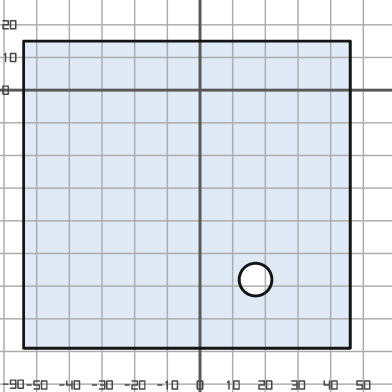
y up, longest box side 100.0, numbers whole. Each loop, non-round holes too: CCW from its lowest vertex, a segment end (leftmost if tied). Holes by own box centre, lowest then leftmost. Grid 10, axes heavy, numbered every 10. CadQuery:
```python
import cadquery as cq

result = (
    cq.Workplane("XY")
    .moveTo(-54.0, -79.0)
    .lineTo(46.0, -79.0)
    .lineTo(46.0, 15.0)
    .lineTo(-54.0, 15.0)
    .close()
    .moveTo(17.0, -58.0)
    .circle(5.0)
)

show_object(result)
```